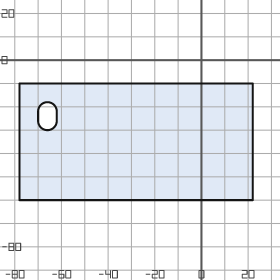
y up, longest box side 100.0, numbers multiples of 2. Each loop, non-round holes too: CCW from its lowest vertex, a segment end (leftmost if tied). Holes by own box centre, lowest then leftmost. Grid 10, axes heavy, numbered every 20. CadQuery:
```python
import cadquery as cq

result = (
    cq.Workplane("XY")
    .moveTo(-78.0, -60.0)
    .lineTo(22.0, -60.0)
    .lineTo(22.0, -10.0)
    .lineTo(-78.0, -10.0)
    .close()
    .moveTo(-70.0, -26.0)
    .threePointArc((-66.0, -30.0), (-62.0, -26.0))
    .lineTo(-62.0, -22.0)
    .threePointArc((-66.0, -18.0), (-70.0, -22.0))
    .close()
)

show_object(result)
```